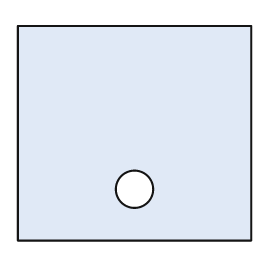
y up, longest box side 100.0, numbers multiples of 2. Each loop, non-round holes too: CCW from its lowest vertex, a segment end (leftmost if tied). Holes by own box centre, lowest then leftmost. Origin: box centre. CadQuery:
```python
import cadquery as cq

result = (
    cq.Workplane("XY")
    .moveTo(-50.0, -46.0)
    .lineTo(50.0, -46.0)
    .lineTo(50.0, 46.0)
    .lineTo(-50.0, 46.0)
    .close()
    .moveTo(0.0, -24.0)
    .circle(8.0)
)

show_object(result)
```